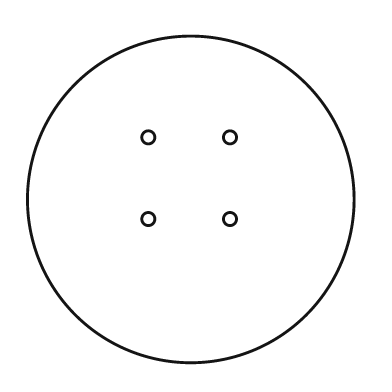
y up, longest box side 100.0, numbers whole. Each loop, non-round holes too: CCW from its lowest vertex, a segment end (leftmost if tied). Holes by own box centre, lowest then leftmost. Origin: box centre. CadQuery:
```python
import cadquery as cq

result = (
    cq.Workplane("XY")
    .moveTo(0.0, 0.0)
    .circle(50.0)
    .moveTo(-13.0, -6.0)
    .circle(2.0)
    .moveTo(12.0, -6.0)
    .circle(2.0)
    .moveTo(-13.0, 19.0)
    .circle(2.0)
    .moveTo(12.0, 19.0)
    .circle(2.0)
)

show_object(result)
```